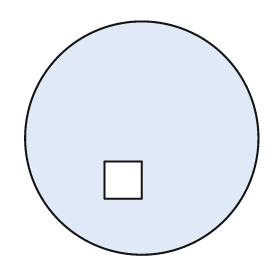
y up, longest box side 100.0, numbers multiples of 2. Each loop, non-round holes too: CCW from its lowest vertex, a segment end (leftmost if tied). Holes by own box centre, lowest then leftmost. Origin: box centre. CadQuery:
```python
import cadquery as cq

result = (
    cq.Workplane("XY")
    .moveTo(0.0, 0.0)
    .circle(50.0)
    .moveTo(-16.0, -26.0)
    .lineTo(0.0, -26.0)
    .lineTo(0.0, -10.0)
    .lineTo(-16.0, -10.0)
    .close()
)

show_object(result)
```